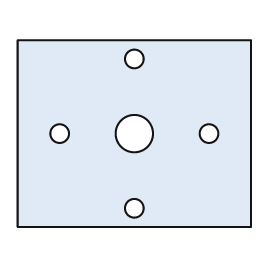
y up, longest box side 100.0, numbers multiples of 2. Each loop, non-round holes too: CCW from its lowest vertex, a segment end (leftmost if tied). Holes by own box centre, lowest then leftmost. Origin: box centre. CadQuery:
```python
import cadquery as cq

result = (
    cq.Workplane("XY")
    .moveTo(-50.0, -40.0)
    .lineTo(50.0, -40.0)
    .lineTo(50.0, 40.0)
    .lineTo(-50.0, 40.0)
    .close()
    .moveTo(0.0, -32.0)
    .circle(4.0)
    .moveTo(-32.0, 0.0)
    .circle(4.0)
    .moveTo(0.0, 0.0)
    .circle(8.0)
    .moveTo(32.0, 0.0)
    .circle(4.0)
    .moveTo(0.0, 32.0)
    .circle(4.0)
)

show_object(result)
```